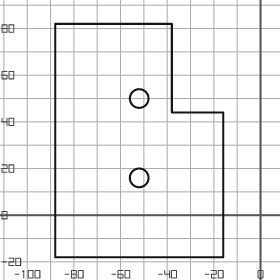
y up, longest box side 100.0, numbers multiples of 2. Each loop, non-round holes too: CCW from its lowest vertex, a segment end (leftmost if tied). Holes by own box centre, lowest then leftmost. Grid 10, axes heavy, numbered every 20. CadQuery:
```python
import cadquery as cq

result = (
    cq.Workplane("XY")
    .moveTo(-88.0, -18.0)
    .lineTo(-16.0, -18.0)
    .lineTo(-16.0, 44.0)
    .lineTo(-38.0, 44.0)
    .lineTo(-38.0, 82.0)
    .lineTo(-88.0, 82.0)
    .close()
    .moveTo(-52.0, 16.0)
    .circle(4.0)
    .moveTo(-52.0, 50.0)
    .circle(4.0)
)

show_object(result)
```